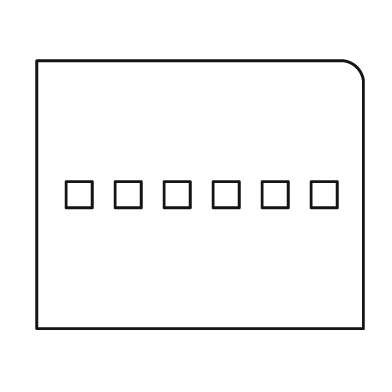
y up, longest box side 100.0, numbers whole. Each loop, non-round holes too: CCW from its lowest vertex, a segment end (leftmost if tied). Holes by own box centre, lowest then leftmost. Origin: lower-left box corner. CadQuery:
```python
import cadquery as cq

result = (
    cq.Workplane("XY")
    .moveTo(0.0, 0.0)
    .lineTo(100.0, 0.0)
    .lineTo(100.0, 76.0)
    .threePointArc((98.0, 80.0), (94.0, 82.0))
    .lineTo(0.0, 82.0)
    .close()
    .moveTo(9.0, 37.0)
    .lineTo(17.0, 37.0)
    .lineTo(17.0, 45.0)
    .lineTo(9.0, 45.0)
    .close()
    .moveTo(24.0, 37.0)
    .lineTo(32.0, 37.0)
    .lineTo(32.0, 45.0)
    .lineTo(24.0, 45.0)
    .close()
    .moveTo(39.0, 37.0)
    .lineTo(47.0, 37.0)
    .lineTo(47.0, 45.0)
    .lineTo(39.0, 45.0)
    .close()
    .moveTo(54.0, 37.0)
    .lineTo(62.0, 37.0)
    .lineTo(62.0, 45.0)
    .lineTo(54.0, 45.0)
    .close()
    .moveTo(69.0, 37.0)
    .lineTo(77.0, 37.0)
    .lineTo(77.0, 45.0)
    .lineTo(69.0, 45.0)
    .close()
    .moveTo(84.0, 37.0)
    .lineTo(92.0, 37.0)
    .lineTo(92.0, 45.0)
    .lineTo(84.0, 45.0)
    .close()
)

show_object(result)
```